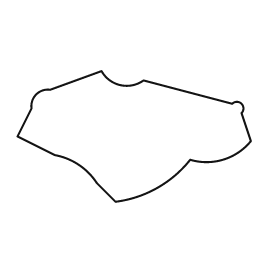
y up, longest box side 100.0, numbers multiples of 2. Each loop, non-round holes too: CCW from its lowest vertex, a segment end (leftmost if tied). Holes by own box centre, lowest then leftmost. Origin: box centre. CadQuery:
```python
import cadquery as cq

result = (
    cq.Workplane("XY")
    .moveTo(-8.0, -28.0)
    .threePointArc((10.0, -22.0), (24.0, -10.0))
    .threePointArc((38.0, -10.0), (50.0, -2.0))
    .lineTo(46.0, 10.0)
    .threePointArc((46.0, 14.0), (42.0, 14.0))
    .lineTo(4.0, 24.0)
    .threePointArc((-6.0, 22.0), (-14.0, 28.0))
    .lineTo(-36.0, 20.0)
    .threePointArc((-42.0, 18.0), (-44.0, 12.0))
    .lineTo(-50.0, 0.0)
    .lineTo(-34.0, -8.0)
    .threePointArc((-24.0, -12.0), (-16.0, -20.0))
    .close()
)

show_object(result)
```